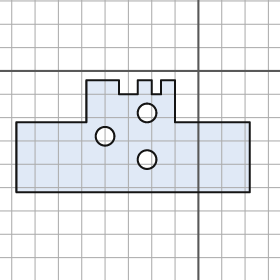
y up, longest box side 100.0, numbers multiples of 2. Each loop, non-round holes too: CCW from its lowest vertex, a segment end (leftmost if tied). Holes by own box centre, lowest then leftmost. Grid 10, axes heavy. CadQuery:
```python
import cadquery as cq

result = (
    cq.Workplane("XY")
    .moveTo(-78.0, -52.0)
    .lineTo(22.0, -52.0)
    .lineTo(22.0, -22.0)
    .lineTo(-10.0, -22.0)
    .lineTo(-10.0, -4.0)
    .lineTo(-16.0, -4.0)
    .lineTo(-16.0, -10.0)
    .lineTo(-20.0, -10.0)
    .lineTo(-20.0, -4.0)
    .lineTo(-26.0, -4.0)
    .lineTo(-26.0, -10.0)
    .lineTo(-34.0, -10.0)
    .lineTo(-34.0, -4.0)
    .lineTo(-48.0, -4.0)
    .lineTo(-48.0, -22.0)
    .lineTo(-78.0, -22.0)
    .close()
    .moveTo(-22.0, -38.0)
    .circle(4.0)
    .moveTo(-40.0, -28.0)
    .circle(4.0)
    .moveTo(-22.0, -18.0)
    .circle(4.0)
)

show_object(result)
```